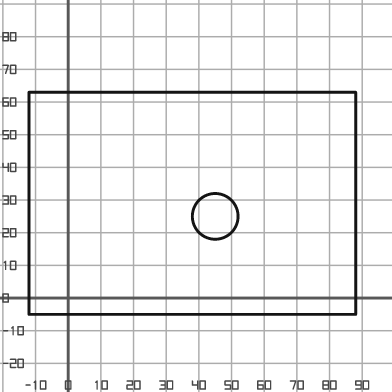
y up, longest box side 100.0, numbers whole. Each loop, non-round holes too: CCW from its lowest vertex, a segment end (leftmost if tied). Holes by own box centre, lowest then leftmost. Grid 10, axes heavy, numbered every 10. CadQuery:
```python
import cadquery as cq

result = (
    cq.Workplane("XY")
    .moveTo(-12.0, -5.0)
    .lineTo(88.0, -5.0)
    .lineTo(88.0, 63.0)
    .lineTo(-12.0, 63.0)
    .close()
    .moveTo(45.0, 25.0)
    .circle(7.0)
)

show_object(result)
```